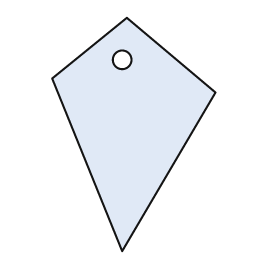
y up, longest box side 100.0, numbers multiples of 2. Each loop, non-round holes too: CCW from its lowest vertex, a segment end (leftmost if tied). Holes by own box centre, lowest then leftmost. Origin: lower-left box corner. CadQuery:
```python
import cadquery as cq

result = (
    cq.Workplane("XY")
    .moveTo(30.0, 0.0)
    .lineTo(70.0, 68.0)
    .lineTo(32.0, 100.0)
    .lineTo(0.0, 74.0)
    .close()
    .moveTo(30.0, 82.0)
    .circle(4.0)
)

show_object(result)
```